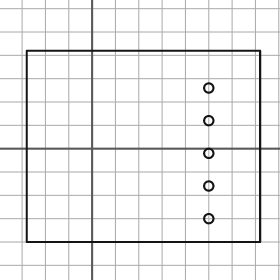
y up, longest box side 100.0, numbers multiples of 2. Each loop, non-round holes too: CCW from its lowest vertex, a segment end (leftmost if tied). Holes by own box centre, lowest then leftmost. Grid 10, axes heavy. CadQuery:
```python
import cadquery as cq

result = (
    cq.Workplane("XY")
    .moveTo(-28.0, -40.0)
    .lineTo(72.0, -40.0)
    .lineTo(72.0, 42.0)
    .lineTo(-28.0, 42.0)
    .close()
    .moveTo(50.0, -30.0)
    .circle(2.0)
    .moveTo(50.0, -16.0)
    .circle(2.0)
    .moveTo(50.0, -2.0)
    .circle(2.0)
    .moveTo(50.0, 12.0)
    .circle(2.0)
    .moveTo(50.0, 26.0)
    .circle(2.0)
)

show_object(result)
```